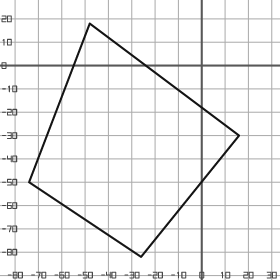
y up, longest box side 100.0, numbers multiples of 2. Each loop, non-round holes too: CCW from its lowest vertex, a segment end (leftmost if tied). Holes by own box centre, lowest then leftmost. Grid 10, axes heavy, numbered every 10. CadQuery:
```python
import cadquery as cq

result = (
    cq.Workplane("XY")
    .moveTo(-26.0, -82.0)
    .lineTo(16.0, -30.0)
    .lineTo(-48.0, 18.0)
    .lineTo(-74.0, -50.0)
    .close()
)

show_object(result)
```